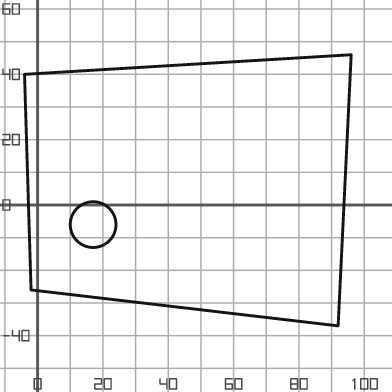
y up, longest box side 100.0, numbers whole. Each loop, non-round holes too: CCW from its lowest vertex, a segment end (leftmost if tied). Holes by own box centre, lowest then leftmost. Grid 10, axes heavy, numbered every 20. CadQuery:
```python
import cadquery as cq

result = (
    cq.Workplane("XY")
    .moveTo(92.0, -37.0)
    .lineTo(96.0, 46.0)
    .lineTo(-4.0, 40.0)
    .lineTo(-2.0, -26.0)
    .close()
    .moveTo(17.0, -6.0)
    .circle(7.0)
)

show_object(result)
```